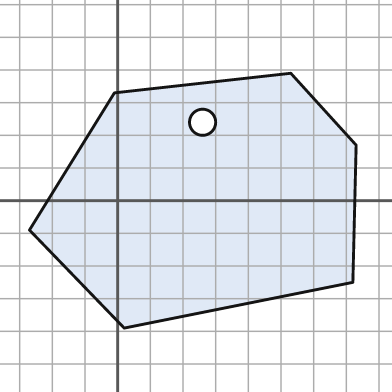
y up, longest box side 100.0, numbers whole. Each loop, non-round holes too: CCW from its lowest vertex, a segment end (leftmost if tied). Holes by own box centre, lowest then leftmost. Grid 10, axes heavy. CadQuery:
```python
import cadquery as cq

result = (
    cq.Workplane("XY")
    .moveTo(2.0, -39.0)
    .lineTo(72.0, -25.0)
    .lineTo(73.0, 17.0)
    .lineTo(53.0, 39.0)
    .lineTo(-1.0, 33.0)
    .lineTo(-27.0, -9.0)
    .close()
    .moveTo(26.0, 24.0)
    .circle(4.0)
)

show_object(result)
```